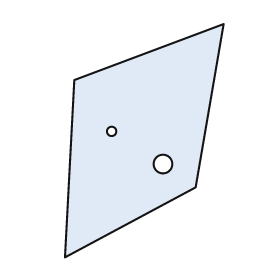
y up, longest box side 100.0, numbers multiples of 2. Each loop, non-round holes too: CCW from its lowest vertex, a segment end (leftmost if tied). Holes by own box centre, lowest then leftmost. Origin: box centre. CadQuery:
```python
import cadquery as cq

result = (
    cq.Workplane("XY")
    .moveTo(-34.0, -50.0)
    .lineTo(22.0, -20.0)
    .lineTo(34.0, 50.0)
    .lineTo(-30.0, 26.0)
    .close()
    .moveTo(8.0, -10.0)
    .circle(4.0)
    .moveTo(-14.0, 4.0)
    .circle(2.0)
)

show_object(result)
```